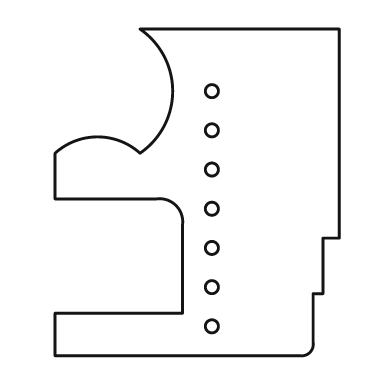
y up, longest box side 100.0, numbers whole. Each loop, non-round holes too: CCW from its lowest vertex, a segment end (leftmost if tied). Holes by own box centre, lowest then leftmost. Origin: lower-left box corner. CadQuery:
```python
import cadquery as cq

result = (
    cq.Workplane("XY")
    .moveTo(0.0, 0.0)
    .lineTo(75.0, 0.0)
    .threePointArc((78.0, 1.0), (79.0, 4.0))
    .lineTo(79.0, 19.0)
    .lineTo(82.0, 19.0)
    .lineTo(82.0, 36.0)
    .lineTo(87.0, 36.0)
    .lineTo(87.0, 100.0)
    .lineTo(26.0, 100.0)
    .threePointArc((36.0, 81.0), (26.0, 62.0))
    .threePointArc((13.0, 67.0), (0.0, 62.0))
    .lineTo(0.0, 48.0)
    .lineTo(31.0, 48.0)
    .threePointArc((37.0, 46.0), (39.0, 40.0))
    .lineTo(39.0, 13.0)
    .lineTo(0.0, 13.0)
    .close()
    .moveTo(48.0, 9.0)
    .circle(2.0)
    .moveTo(48.0, 21.0)
    .circle(2.0)
    .moveTo(48.0, 33.0)
    .circle(2.0)
    .moveTo(48.0, 45.0)
    .circle(2.0)
    .moveTo(48.0, 57.0)
    .circle(2.0)
    .moveTo(48.0, 69.0)
    .circle(2.0)
    .moveTo(48.0, 81.0)
    .circle(2.0)
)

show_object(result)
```